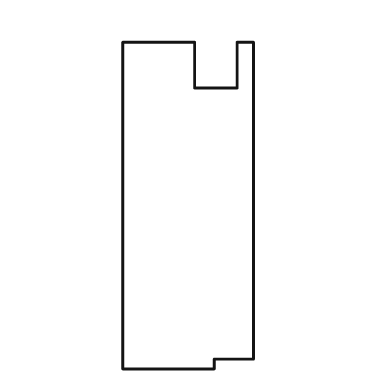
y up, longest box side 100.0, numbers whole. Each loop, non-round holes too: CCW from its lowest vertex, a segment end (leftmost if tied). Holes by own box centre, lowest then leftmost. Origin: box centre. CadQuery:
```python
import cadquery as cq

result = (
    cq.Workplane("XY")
    .moveTo(-20.0, -50.0)
    .lineTo(8.0, -50.0)
    .lineTo(8.0, -47.0)
    .lineTo(20.0, -47.0)
    .lineTo(20.0, 50.0)
    .lineTo(15.0, 50.0)
    .lineTo(15.0, 36.0)
    .lineTo(2.0, 36.0)
    .lineTo(2.0, 50.0)
    .lineTo(-20.0, 50.0)
    .close()
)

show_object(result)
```